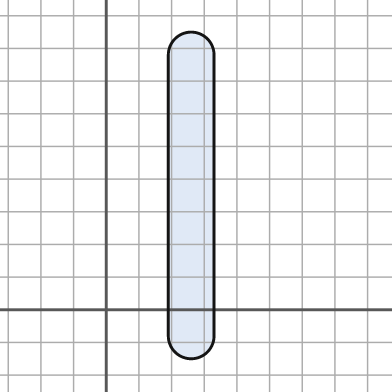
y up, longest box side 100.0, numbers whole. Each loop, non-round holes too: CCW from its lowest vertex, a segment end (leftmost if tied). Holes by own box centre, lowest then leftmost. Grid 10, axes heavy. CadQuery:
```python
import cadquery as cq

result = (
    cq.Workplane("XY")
    .moveTo(19.0, -8.0)
    .threePointArc((26.0, -15.0), (33.0, -8.0))
    .lineTo(33.0, 78.0)
    .threePointArc((26.0, 85.0), (19.0, 78.0))
    .close()
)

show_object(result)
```